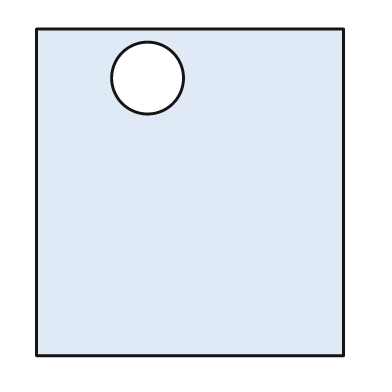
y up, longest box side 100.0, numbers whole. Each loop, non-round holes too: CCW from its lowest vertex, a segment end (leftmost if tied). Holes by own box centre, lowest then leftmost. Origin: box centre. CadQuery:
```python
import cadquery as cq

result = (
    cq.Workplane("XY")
    .moveTo(-47.0, -50.0)
    .lineTo(47.0, -50.0)
    .lineTo(47.0, 50.0)
    .lineTo(-47.0, 50.0)
    .close()
    .moveTo(-13.0, 35.0)
    .circle(11.0)
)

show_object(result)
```